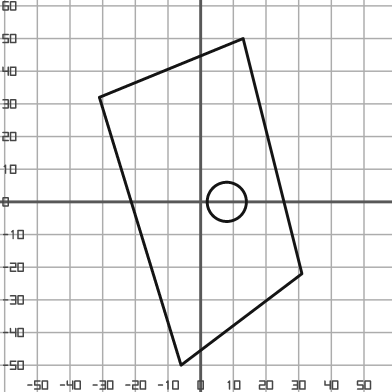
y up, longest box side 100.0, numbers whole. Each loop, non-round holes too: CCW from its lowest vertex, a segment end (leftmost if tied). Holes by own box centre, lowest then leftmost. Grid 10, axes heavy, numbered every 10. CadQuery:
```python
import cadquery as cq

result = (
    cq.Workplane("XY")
    .moveTo(-6.0, -50.0)
    .lineTo(31.0, -22.0)
    .lineTo(13.0, 50.0)
    .lineTo(-31.0, 32.0)
    .close()
    .moveTo(8.0, 0.0)
    .circle(6.0)
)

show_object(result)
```